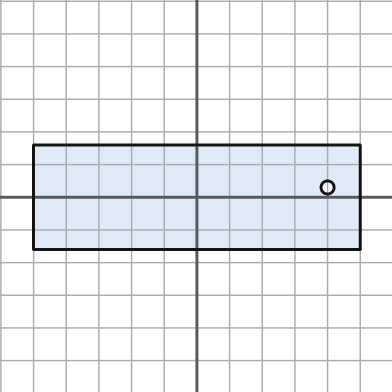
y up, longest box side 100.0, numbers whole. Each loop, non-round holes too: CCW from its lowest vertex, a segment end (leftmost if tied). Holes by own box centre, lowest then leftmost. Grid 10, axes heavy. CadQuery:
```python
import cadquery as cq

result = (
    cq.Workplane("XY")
    .moveTo(-50.0, -16.0)
    .lineTo(50.0, -16.0)
    .lineTo(50.0, 16.0)
    .lineTo(-50.0, 16.0)
    .close()
    .moveTo(40.0, 3.0)
    .circle(2.0)
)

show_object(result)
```